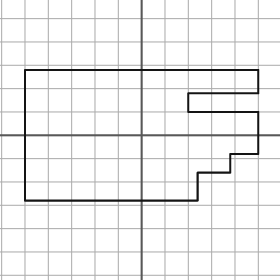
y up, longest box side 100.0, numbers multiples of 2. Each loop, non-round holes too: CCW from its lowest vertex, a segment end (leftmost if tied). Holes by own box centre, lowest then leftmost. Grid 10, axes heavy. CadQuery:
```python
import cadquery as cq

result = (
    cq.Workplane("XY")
    .moveTo(-50.0, -28.0)
    .lineTo(24.0, -28.0)
    .lineTo(24.0, -16.0)
    .lineTo(38.0, -16.0)
    .lineTo(38.0, -8.0)
    .lineTo(50.0, -8.0)
    .lineTo(50.0, 10.0)
    .lineTo(20.0, 10.0)
    .lineTo(20.0, 18.0)
    .lineTo(50.0, 18.0)
    .lineTo(50.0, 28.0)
    .lineTo(-50.0, 28.0)
    .close()
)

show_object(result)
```